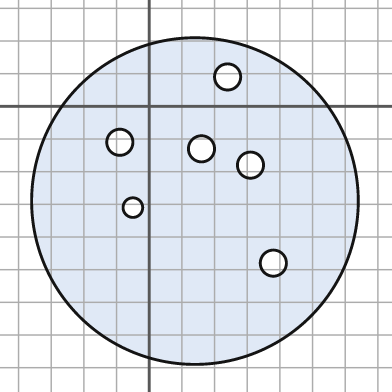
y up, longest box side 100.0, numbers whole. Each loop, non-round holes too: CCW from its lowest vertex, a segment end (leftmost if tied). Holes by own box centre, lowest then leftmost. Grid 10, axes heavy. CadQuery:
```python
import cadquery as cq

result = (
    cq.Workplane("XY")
    .moveTo(14.0, -29.0)
    .circle(50.0)
    .moveTo(38.0, -48.0)
    .circle(4.0)
    .moveTo(-5.0, -31.0)
    .circle(3.0)
    .moveTo(31.0, -18.0)
    .circle(4.0)
    .moveTo(16.0, -13.0)
    .circle(4.0)
    .moveTo(-9.0, -11.0)
    .circle(4.0)
    .moveTo(24.0, 9.0)
    .circle(4.0)
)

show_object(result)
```